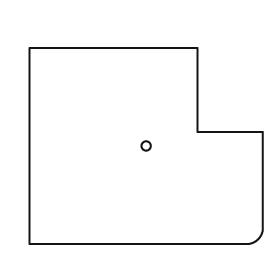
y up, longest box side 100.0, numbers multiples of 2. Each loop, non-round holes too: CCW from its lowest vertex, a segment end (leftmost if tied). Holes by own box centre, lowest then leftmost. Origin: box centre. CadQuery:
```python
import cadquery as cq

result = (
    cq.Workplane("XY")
    .moveTo(-50.0, -42.0)
    .lineTo(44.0, -42.0)
    .threePointArc((48.0, -40.0), (50.0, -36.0))
    .lineTo(50.0, 6.0)
    .lineTo(22.0, 6.0)
    .lineTo(22.0, 42.0)
    .lineTo(-50.0, 42.0)
    .close()
    .moveTo(0.0, 0.0)
    .circle(2.0)
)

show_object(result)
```